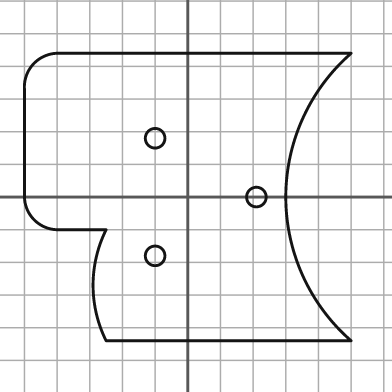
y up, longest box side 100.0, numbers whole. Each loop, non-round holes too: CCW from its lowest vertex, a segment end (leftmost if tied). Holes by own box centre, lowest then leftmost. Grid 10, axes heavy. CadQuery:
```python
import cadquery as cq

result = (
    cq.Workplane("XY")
    .moveTo(-25.0, -44.0)
    .lineTo(50.0, -44.0)
    .threePointArc((30.0, 0.0), (50.0, 44.0))
    .lineTo(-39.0, 44.0)
    .threePointArc((-47.0, 41.0), (-50.0, 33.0))
    .lineTo(-50.0, 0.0)
    .threePointArc((-47.0, -7.0), (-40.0, -10.0))
    .lineTo(-25.0, -10.0)
    .threePointArc((-29.0, -27.0), (-25.0, -44.0))
    .close()
    .moveTo(-10.0, -18.0)
    .circle(3.0)
    .moveTo(21.0, 0.0)
    .circle(3.0)
    .moveTo(-10.0, 18.0)
    .circle(3.0)
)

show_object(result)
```